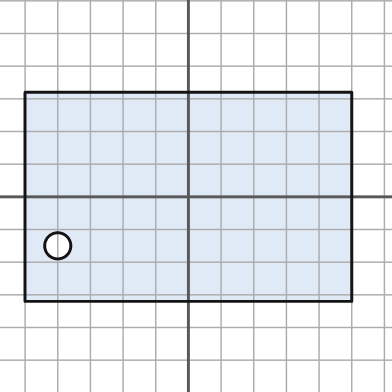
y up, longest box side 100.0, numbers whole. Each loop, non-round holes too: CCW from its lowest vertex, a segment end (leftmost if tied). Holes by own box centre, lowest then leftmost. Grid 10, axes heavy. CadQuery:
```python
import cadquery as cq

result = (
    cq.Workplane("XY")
    .moveTo(-50.0, -32.0)
    .lineTo(50.0, -32.0)
    .lineTo(50.0, 32.0)
    .lineTo(-50.0, 32.0)
    .close()
    .moveTo(-40.0, -15.0)
    .circle(4.0)
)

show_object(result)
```